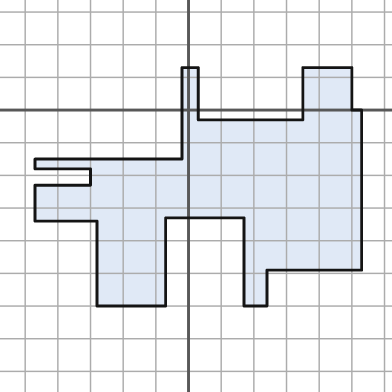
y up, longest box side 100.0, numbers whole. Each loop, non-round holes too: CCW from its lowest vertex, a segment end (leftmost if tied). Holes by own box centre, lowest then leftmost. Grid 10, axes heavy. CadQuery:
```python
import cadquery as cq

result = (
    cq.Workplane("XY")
    .moveTo(-28.0, -60.0)
    .lineTo(-7.0, -60.0)
    .lineTo(-7.0, -33.0)
    .lineTo(17.0, -33.0)
    .lineTo(17.0, -60.0)
    .lineTo(24.0, -60.0)
    .lineTo(24.0, -49.0)
    .lineTo(53.0, -49.0)
    .lineTo(53.0, 0.0)
    .lineTo(50.0, 0.0)
    .lineTo(50.0, 13.0)
    .lineTo(35.0, 13.0)
    .lineTo(35.0, -3.0)
    .lineTo(3.0, -3.0)
    .lineTo(3.0, 13.0)
    .lineTo(-2.0, 13.0)
    .lineTo(-2.0, -15.0)
    .lineTo(-47.0, -15.0)
    .lineTo(-47.0, -18.0)
    .lineTo(-30.0, -18.0)
    .lineTo(-30.0, -23.0)
    .lineTo(-47.0, -23.0)
    .lineTo(-47.0, -34.0)
    .lineTo(-28.0, -34.0)
    .close()
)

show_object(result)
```